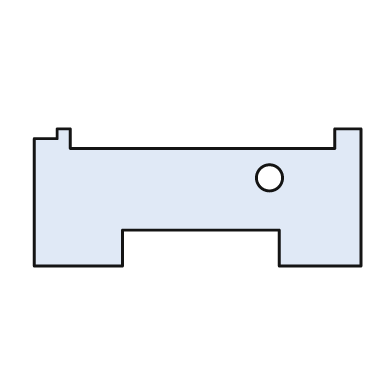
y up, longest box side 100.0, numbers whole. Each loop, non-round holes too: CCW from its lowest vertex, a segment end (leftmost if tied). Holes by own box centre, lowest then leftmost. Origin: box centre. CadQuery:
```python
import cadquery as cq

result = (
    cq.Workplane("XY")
    .moveTo(-50.0, -21.0)
    .lineTo(-23.0, -21.0)
    .lineTo(-23.0, -10.0)
    .lineTo(25.0, -10.0)
    .lineTo(25.0, -21.0)
    .lineTo(50.0, -21.0)
    .lineTo(50.0, 21.0)
    .lineTo(42.0, 21.0)
    .lineTo(42.0, 15.0)
    .lineTo(-39.0, 15.0)
    .lineTo(-39.0, 21.0)
    .lineTo(-43.0, 21.0)
    .lineTo(-43.0, 18.0)
    .lineTo(-50.0, 18.0)
    .close()
    .moveTo(22.0, 6.0)
    .circle(4.0)
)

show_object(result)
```